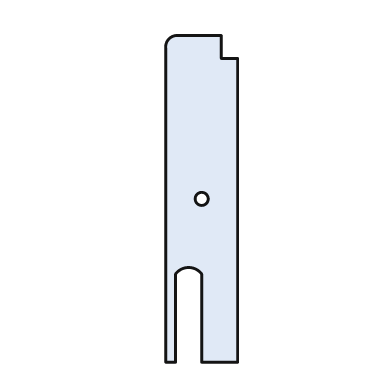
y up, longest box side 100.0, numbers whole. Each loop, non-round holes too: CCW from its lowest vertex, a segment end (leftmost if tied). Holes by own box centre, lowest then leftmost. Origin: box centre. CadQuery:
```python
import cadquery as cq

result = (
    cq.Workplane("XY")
    .moveTo(-11.0, -50.0)
    .lineTo(-8.0, -50.0)
    .lineTo(-8.0, -23.0)
    .threePointArc((-4.0, -21.0), (0.0, -23.0))
    .lineTo(0.0, -50.0)
    .lineTo(11.0, -50.0)
    .lineTo(11.0, 43.0)
    .lineTo(6.0, 43.0)
    .lineTo(6.0, 50.0)
    .lineTo(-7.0, 50.0)
    .threePointArc((-10.0, 49.0), (-11.0, 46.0))
    .close()
    .moveTo(0.0, 0.0)
    .circle(2.0)
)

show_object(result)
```